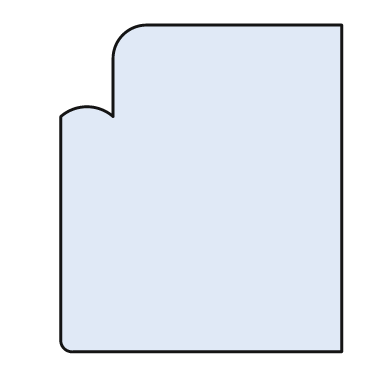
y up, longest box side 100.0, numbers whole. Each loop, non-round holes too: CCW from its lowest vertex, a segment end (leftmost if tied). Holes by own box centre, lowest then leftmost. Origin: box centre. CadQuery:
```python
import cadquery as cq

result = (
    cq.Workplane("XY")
    .moveTo(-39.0, -50.0)
    .lineTo(43.0, -50.0)
    .lineTo(43.0, 50.0)
    .lineTo(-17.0, 50.0)
    .threePointArc((-24.0, 47.0), (-27.0, 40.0))
    .lineTo(-27.0, 22.0)
    .threePointArc((-35.0, 25.0), (-43.0, 22.0))
    .lineTo(-43.0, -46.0)
    .threePointArc((-42.0, -49.0), (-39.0, -50.0))
    .close()
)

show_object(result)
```